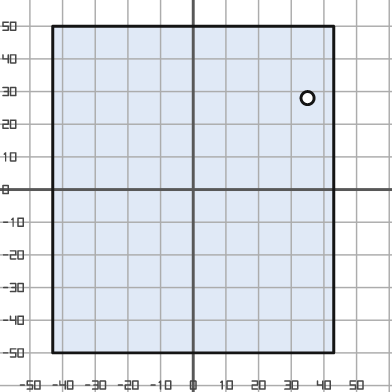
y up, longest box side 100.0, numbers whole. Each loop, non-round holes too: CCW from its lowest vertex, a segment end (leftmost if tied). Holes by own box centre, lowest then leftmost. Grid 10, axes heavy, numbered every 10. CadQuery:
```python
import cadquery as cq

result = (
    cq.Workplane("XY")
    .moveTo(-43.0, -50.0)
    .lineTo(43.0, -50.0)
    .lineTo(43.0, 50.0)
    .lineTo(-43.0, 50.0)
    .close()
    .moveTo(35.0, 28.0)
    .circle(2.0)
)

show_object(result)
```